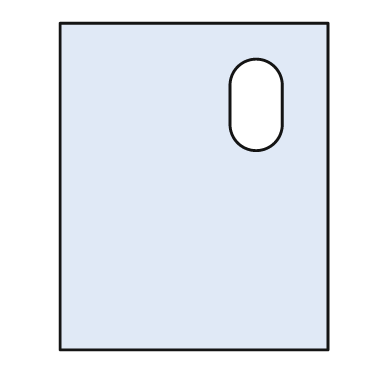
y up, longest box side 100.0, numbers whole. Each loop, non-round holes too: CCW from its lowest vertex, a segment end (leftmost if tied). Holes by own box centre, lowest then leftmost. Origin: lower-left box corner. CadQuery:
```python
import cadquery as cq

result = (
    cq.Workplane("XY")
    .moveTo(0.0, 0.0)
    .lineTo(82.0, 0.0)
    .lineTo(82.0, 100.0)
    .lineTo(0.0, 100.0)
    .close()
    .moveTo(52.0, 69.0)
    .threePointArc((60.0, 61.0), (68.0, 69.0))
    .lineTo(68.0, 81.0)
    .threePointArc((60.0, 89.0), (52.0, 81.0))
    .close()
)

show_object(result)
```